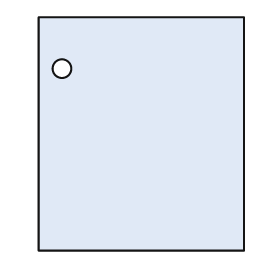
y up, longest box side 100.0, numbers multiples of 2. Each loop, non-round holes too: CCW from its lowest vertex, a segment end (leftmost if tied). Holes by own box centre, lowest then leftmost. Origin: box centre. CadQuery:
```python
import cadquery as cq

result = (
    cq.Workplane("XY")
    .moveTo(-44.0, -50.0)
    .lineTo(44.0, -50.0)
    .lineTo(44.0, 50.0)
    .lineTo(-44.0, 50.0)
    .close()
    .moveTo(-34.0, 28.0)
    .circle(4.0)
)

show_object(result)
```